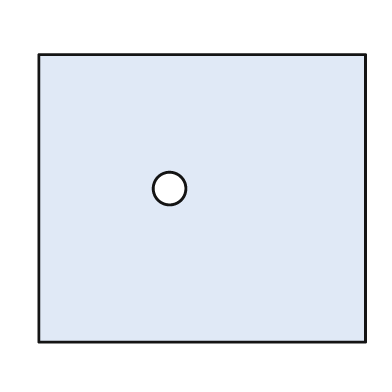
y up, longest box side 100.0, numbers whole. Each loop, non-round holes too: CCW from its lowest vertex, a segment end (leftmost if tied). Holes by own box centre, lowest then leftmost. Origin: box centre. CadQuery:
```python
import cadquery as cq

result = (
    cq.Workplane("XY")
    .moveTo(-50.0, -44.0)
    .lineTo(50.0, -44.0)
    .lineTo(50.0, 44.0)
    .lineTo(-50.0, 44.0)
    .close()
    .moveTo(-10.0, 3.0)
    .circle(5.0)
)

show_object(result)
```